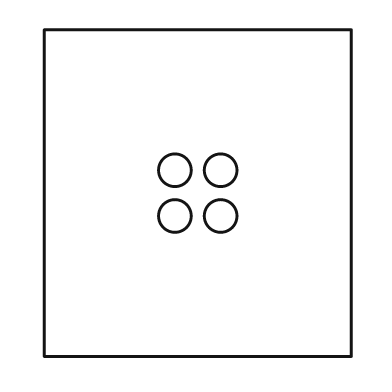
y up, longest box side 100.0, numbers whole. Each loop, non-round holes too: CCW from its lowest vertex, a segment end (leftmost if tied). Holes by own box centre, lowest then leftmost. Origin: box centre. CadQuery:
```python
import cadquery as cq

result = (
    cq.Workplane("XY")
    .moveTo(-47.0, -50.0)
    .lineTo(47.0, -50.0)
    .lineTo(47.0, 50.0)
    .lineTo(-47.0, 50.0)
    .close()
    .moveTo(-7.0, -7.0)
    .circle(5.0)
    .moveTo(7.0, -7.0)
    .circle(5.0)
    .moveTo(-7.0, 7.0)
    .circle(5.0)
    .moveTo(7.0, 7.0)
    .circle(5.0)
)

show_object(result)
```